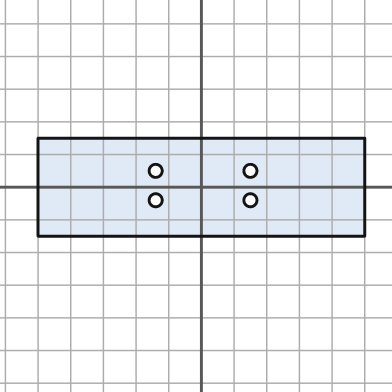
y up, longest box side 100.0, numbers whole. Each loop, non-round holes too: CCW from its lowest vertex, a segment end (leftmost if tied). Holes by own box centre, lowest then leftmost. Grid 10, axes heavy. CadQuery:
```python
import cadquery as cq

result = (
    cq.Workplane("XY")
    .moveTo(-50.0, -15.0)
    .lineTo(50.0, -15.0)
    .lineTo(50.0, 15.0)
    .lineTo(-50.0, 15.0)
    .close()
    .moveTo(-14.0, -4.0)
    .circle(2.0)
    .moveTo(15.0, -4.0)
    .circle(2.0)
    .moveTo(-14.0, 5.0)
    .circle(2.0)
    .moveTo(15.0, 5.0)
    .circle(2.0)
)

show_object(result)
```